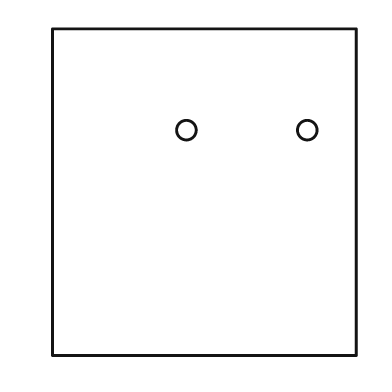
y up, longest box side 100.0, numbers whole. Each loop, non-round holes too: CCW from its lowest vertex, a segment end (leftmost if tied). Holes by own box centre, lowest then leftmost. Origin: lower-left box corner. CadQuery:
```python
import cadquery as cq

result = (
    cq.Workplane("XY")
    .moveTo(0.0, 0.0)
    .lineTo(93.0, 0.0)
    .lineTo(93.0, 100.0)
    .lineTo(0.0, 100.0)
    .close()
    .moveTo(41.0, 69.0)
    .circle(3.0)
    .moveTo(78.0, 69.0)
    .circle(3.0)
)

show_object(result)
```